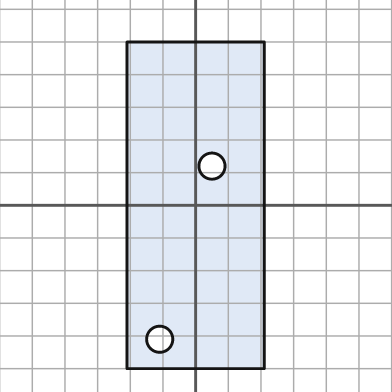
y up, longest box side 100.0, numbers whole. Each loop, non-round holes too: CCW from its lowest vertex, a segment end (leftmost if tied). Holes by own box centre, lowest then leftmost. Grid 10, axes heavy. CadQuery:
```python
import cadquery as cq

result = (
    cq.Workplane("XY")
    .moveTo(-21.0, -50.0)
    .lineTo(21.0, -50.0)
    .lineTo(21.0, 50.0)
    .lineTo(-21.0, 50.0)
    .close()
    .moveTo(-11.0, -41.0)
    .circle(4.0)
    .moveTo(5.0, 12.0)
    .circle(4.0)
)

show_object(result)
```